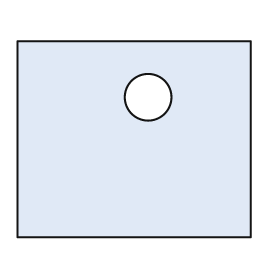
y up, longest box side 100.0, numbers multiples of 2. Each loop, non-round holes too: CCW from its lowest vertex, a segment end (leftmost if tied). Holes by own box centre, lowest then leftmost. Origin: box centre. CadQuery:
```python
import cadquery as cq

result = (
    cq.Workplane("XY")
    .moveTo(-50.0, -42.0)
    .lineTo(50.0, -42.0)
    .lineTo(50.0, 42.0)
    .lineTo(-50.0, 42.0)
    .close()
    .moveTo(6.0, 18.0)
    .circle(10.0)
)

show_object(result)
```